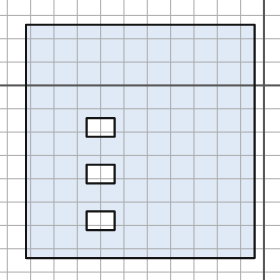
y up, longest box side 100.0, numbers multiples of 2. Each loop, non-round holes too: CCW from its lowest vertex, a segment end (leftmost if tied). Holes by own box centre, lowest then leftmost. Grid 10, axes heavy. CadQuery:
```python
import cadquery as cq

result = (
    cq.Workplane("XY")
    .moveTo(-102.0, -74.0)
    .lineTo(-4.0, -74.0)
    .lineTo(-4.0, 26.0)
    .lineTo(-102.0, 26.0)
    .close()
    .moveTo(-76.0, -62.0)
    .lineTo(-64.0, -62.0)
    .lineTo(-64.0, -54.0)
    .lineTo(-76.0, -54.0)
    .close()
    .moveTo(-76.0, -42.0)
    .lineTo(-64.0, -42.0)
    .lineTo(-64.0, -34.0)
    .lineTo(-76.0, -34.0)
    .close()
    .moveTo(-76.0, -22.0)
    .lineTo(-64.0, -22.0)
    .lineTo(-64.0, -14.0)
    .lineTo(-76.0, -14.0)
    .close()
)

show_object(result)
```